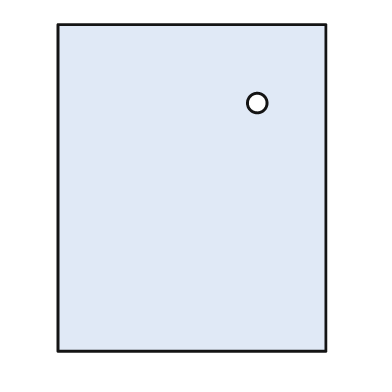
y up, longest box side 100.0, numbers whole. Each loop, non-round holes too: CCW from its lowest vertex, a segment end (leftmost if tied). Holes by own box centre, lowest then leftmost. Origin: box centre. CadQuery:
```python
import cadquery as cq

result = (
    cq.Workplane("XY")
    .moveTo(-41.0, -50.0)
    .lineTo(41.0, -50.0)
    .lineTo(41.0, 50.0)
    .lineTo(-41.0, 50.0)
    .close()
    .moveTo(20.0, 26.0)
    .circle(3.0)
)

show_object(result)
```